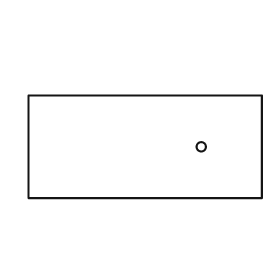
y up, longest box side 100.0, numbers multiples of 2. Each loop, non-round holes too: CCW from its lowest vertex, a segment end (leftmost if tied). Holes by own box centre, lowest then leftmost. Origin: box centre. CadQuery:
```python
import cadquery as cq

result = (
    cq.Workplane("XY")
    .moveTo(-50.0, -22.0)
    .lineTo(50.0, -22.0)
    .lineTo(50.0, 22.0)
    .lineTo(-50.0, 22.0)
    .close()
    .moveTo(24.0, 0.0)
    .circle(2.0)
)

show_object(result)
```